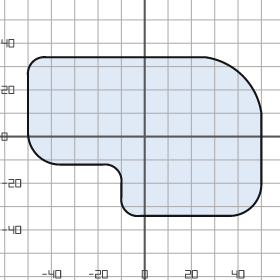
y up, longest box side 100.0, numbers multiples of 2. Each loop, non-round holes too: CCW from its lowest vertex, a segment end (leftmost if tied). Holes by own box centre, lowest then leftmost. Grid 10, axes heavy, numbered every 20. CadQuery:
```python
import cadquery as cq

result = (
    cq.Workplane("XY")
    .moveTo(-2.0, -34.0)
    .lineTo(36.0, -34.0)
    .threePointArc((46.0, -30.0), (50.0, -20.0))
    .lineTo(50.0, 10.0)
    .threePointArc((42.0, 26.0), (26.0, 34.0))
    .lineTo(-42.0, 34.0)
    .threePointArc((-48.0, 32.0), (-50.0, 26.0))
    .lineTo(-50.0, 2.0)
    .threePointArc((-46.0, -8.0), (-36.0, -12.0))
    .lineTo(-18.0, -12.0)
    .threePointArc((-12.0, -14.0), (-10.0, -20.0))
    .lineTo(-10.0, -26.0)
    .threePointArc((-8.0, -32.0), (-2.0, -34.0))
    .close()
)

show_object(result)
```